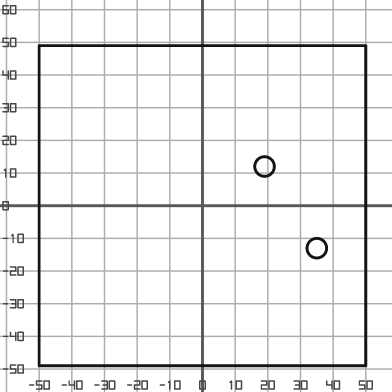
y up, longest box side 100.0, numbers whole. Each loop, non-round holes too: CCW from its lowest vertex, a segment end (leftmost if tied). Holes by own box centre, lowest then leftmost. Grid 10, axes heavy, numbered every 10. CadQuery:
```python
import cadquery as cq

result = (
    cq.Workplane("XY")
    .moveTo(-50.0, -49.0)
    .lineTo(50.0, -49.0)
    .lineTo(50.0, 49.0)
    .lineTo(-50.0, 49.0)
    .close()
    .moveTo(35.0, -13.0)
    .circle(3.0)
    .moveTo(19.0, 12.0)
    .circle(3.0)
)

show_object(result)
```